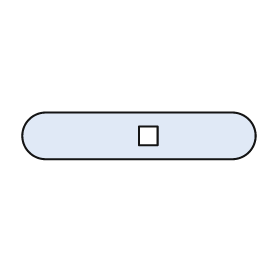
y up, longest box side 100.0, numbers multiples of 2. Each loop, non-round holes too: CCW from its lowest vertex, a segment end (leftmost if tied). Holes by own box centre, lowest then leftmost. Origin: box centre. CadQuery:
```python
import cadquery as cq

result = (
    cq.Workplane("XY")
    .moveTo(-40.0, -10.0)
    .lineTo(40.0, -10.0)
    .threePointArc((50.0, 0.0), (40.0, 10.0))
    .lineTo(-40.0, 10.0)
    .threePointArc((-50.0, 0.0), (-40.0, -10.0))
    .close()
    .moveTo(0.0, -4.0)
    .lineTo(8.0, -4.0)
    .lineTo(8.0, 4.0)
    .lineTo(0.0, 4.0)
    .close()
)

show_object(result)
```